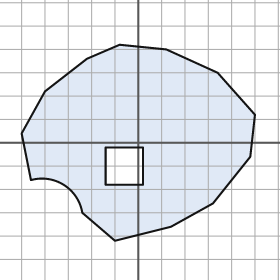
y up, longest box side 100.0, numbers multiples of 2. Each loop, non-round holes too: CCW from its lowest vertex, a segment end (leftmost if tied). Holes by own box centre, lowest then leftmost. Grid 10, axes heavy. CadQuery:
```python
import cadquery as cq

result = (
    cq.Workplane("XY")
    .moveTo(-10.0, -42.0)
    .lineTo(14.0, -36.0)
    .lineTo(32.0, -26.0)
    .lineTo(48.0, -6.0)
    .lineTo(50.0, 12.0)
    .lineTo(34.0, 30.0)
    .lineTo(12.0, 40.0)
    .lineTo(-8.0, 42.0)
    .lineTo(-22.0, 36.0)
    .lineTo(-40.0, 22.0)
    .lineTo(-50.0, 4.0)
    .lineTo(-46.0, -16.0)
    .threePointArc((-32.0, -18.0), (-24.0, -30.0))
    .close()
    .moveTo(-14.0, -18.0)
    .lineTo(2.0, -18.0)
    .lineTo(2.0, -2.0)
    .lineTo(-14.0, -2.0)
    .close()
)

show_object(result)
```